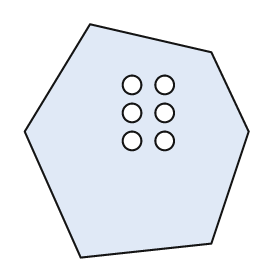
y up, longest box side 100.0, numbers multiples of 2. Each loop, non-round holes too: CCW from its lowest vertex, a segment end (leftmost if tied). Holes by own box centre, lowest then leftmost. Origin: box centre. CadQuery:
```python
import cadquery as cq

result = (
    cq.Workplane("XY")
    .moveTo(-24.0, -50.0)
    .lineTo(32.0, -44.0)
    .lineTo(48.0, 4.0)
    .lineTo(32.0, 38.0)
    .lineTo(-20.0, 50.0)
    .lineTo(-48.0, 4.0)
    .close()
    .moveTo(-2.0, 0.0)
    .circle(4.0)
    .moveTo(12.0, 0.0)
    .circle(4.0)
    .moveTo(-2.0, 12.0)
    .circle(4.0)
    .moveTo(12.0, 12.0)
    .circle(4.0)
    .moveTo(-2.0, 24.0)
    .circle(4.0)
    .moveTo(12.0, 24.0)
    .circle(4.0)
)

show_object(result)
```